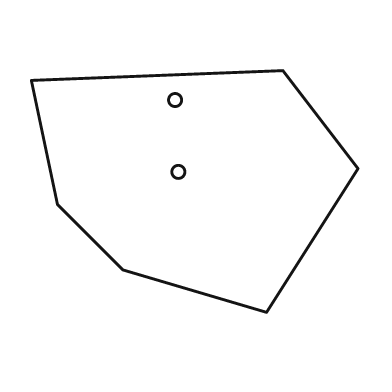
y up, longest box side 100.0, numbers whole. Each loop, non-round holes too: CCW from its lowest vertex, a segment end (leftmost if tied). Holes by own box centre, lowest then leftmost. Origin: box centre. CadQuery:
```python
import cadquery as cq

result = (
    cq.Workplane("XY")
    .moveTo(22.0, -37.0)
    .lineTo(50.0, 7.0)
    .lineTo(27.0, 37.0)
    .lineTo(-50.0, 34.0)
    .lineTo(-42.0, -4.0)
    .lineTo(-22.0, -24.0)
    .close()
    .moveTo(-5.0, 6.0)
    .circle(2.0)
    .moveTo(-6.0, 28.0)
    .circle(2.0)
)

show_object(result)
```